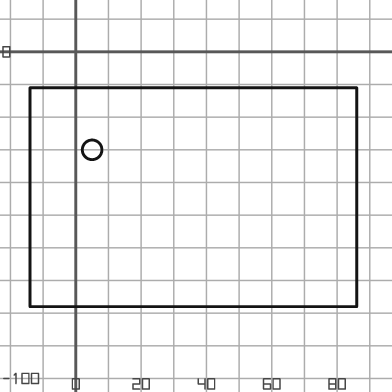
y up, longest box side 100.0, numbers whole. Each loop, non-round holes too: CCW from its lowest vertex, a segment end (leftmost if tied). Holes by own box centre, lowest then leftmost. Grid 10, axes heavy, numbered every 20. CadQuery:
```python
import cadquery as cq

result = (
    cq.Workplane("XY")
    .moveTo(-14.0, -78.0)
    .lineTo(86.0, -78.0)
    .lineTo(86.0, -11.0)
    .lineTo(-14.0, -11.0)
    .close()
    .moveTo(5.0, -30.0)
    .circle(3.0)
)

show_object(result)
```